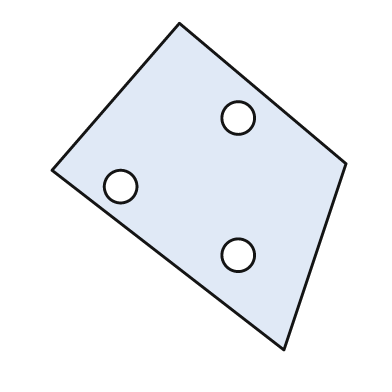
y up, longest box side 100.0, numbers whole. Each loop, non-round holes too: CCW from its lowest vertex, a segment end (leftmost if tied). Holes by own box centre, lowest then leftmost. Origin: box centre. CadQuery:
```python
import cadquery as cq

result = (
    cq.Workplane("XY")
    .moveTo(26.0, -50.0)
    .lineTo(45.0, 7.0)
    .lineTo(-6.0, 50.0)
    .lineTo(-45.0, 5.0)
    .close()
    .moveTo(12.0, -21.0)
    .circle(5.0)
    .moveTo(-24.0, 0.0)
    .circle(5.0)
    .moveTo(12.0, 21.0)
    .circle(5.0)
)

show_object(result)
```